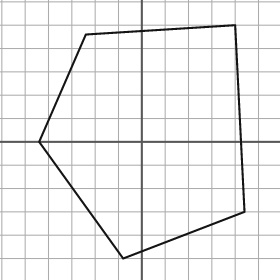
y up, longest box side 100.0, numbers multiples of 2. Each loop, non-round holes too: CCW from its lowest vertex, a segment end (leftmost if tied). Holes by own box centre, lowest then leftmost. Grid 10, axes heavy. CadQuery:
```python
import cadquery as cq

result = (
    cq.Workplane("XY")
    .moveTo(-8.0, -50.0)
    .lineTo(44.0, -30.0)
    .lineTo(40.0, 50.0)
    .lineTo(-24.0, 46.0)
    .lineTo(-44.0, 0.0)
    .close()
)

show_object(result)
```